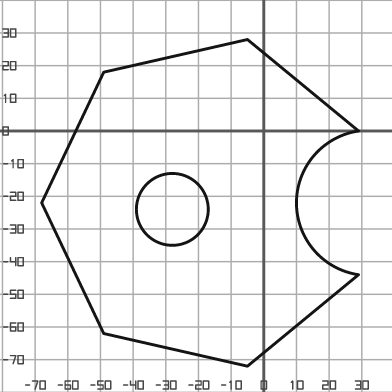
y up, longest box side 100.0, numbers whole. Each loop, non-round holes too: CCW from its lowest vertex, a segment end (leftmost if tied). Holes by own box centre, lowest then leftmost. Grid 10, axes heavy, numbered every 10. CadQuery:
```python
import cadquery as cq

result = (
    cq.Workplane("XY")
    .moveTo(-5.0, -72.0)
    .lineTo(29.0, -44.0)
    .threePointArc((10.0, -22.0), (29.0, 0.0))
    .lineTo(-5.0, 28.0)
    .lineTo(-49.0, 18.0)
    .lineTo(-68.0, -22.0)
    .lineTo(-49.0, -62.0)
    .close()
    .moveTo(-28.0, -24.0)
    .circle(11.0)
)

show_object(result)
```